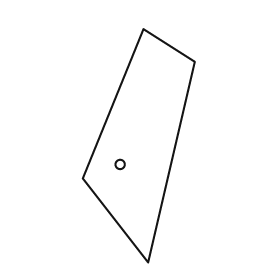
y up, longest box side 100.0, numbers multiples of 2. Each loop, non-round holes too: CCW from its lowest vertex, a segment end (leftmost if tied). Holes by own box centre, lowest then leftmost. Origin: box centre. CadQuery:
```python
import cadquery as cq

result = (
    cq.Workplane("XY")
    .moveTo(4.0, -50.0)
    .lineTo(24.0, 36.0)
    .lineTo(2.0, 50.0)
    .lineTo(-24.0, -14.0)
    .close()
    .moveTo(-8.0, -8.0)
    .circle(2.0)
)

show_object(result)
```